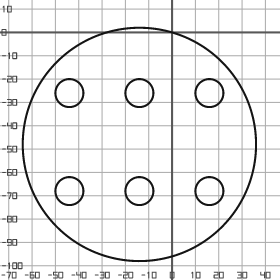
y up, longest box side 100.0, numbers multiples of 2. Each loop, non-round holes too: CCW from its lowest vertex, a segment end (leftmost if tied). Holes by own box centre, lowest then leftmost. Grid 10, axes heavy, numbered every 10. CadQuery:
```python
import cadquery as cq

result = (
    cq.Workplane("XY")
    .moveTo(-14.0, -48.0)
    .circle(50.0)
    .moveTo(-44.0, -68.0)
    .circle(6.0)
    .moveTo(-14.0, -68.0)
    .circle(6.0)
    .moveTo(16.0, -68.0)
    .circle(6.0)
    .moveTo(-44.0, -26.0)
    .circle(6.0)
    .moveTo(-14.0, -26.0)
    .circle(6.0)
    .moveTo(16.0, -26.0)
    .circle(6.0)
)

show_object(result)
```